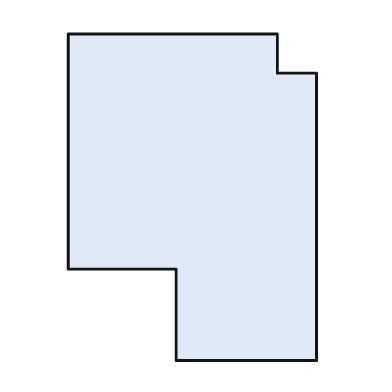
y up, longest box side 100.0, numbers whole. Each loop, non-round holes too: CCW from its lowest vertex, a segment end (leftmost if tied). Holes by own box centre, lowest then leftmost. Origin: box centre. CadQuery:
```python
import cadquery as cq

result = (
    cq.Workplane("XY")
    .moveTo(-5.0, -50.0)
    .lineTo(38.0, -50.0)
    .lineTo(38.0, 38.0)
    .lineTo(26.0, 38.0)
    .lineTo(26.0, 50.0)
    .lineTo(-38.0, 50.0)
    .lineTo(-38.0, -22.0)
    .lineTo(-5.0, -22.0)
    .close()
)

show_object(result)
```